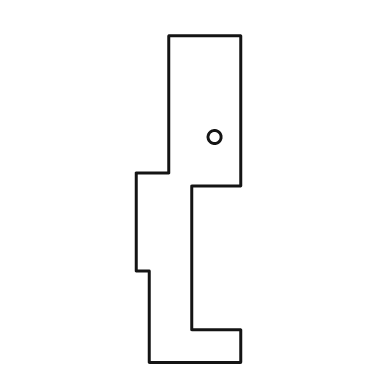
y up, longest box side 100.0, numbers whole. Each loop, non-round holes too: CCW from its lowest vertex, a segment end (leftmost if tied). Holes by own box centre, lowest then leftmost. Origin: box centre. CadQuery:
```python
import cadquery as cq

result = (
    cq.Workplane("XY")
    .moveTo(-12.0, -50.0)
    .lineTo(16.0, -50.0)
    .lineTo(16.0, -40.0)
    .lineTo(1.0, -40.0)
    .lineTo(1.0, 4.0)
    .lineTo(16.0, 4.0)
    .lineTo(16.0, 50.0)
    .lineTo(-6.0, 50.0)
    .lineTo(-6.0, 8.0)
    .lineTo(-16.0, 8.0)
    .lineTo(-16.0, -22.0)
    .lineTo(-12.0, -22.0)
    .close()
    .moveTo(8.0, 19.0)
    .circle(2.0)
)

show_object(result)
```